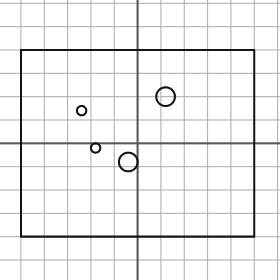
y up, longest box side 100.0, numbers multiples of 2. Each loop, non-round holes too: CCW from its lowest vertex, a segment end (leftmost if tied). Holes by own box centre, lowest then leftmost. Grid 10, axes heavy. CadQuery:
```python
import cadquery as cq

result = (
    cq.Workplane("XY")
    .moveTo(-50.0, -40.0)
    .lineTo(50.0, -40.0)
    .lineTo(50.0, 40.0)
    .lineTo(-50.0, 40.0)
    .close()
    .moveTo(-4.0, -8.0)
    .circle(4.0)
    .moveTo(-18.0, -2.0)
    .circle(2.0)
    .moveTo(-24.0, 14.0)
    .circle(2.0)
    .moveTo(12.0, 20.0)
    .circle(4.0)
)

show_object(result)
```